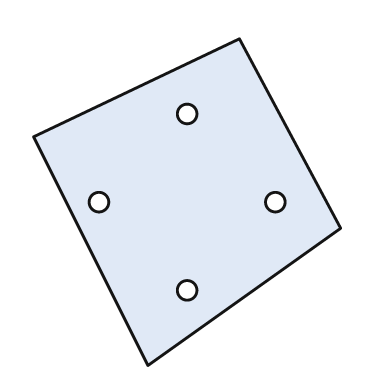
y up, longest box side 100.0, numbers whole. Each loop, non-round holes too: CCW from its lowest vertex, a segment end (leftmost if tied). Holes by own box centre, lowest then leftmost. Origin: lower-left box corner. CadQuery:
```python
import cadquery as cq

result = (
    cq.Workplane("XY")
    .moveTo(35.0, 0.0)
    .lineTo(94.0, 42.0)
    .lineTo(63.0, 100.0)
    .lineTo(0.0, 70.0)
    .close()
    .moveTo(47.0, 23.0)
    .circle(3.0)
    .moveTo(20.0, 50.0)
    .circle(3.0)
    .moveTo(74.0, 50.0)
    .circle(3.0)
    .moveTo(47.0, 77.0)
    .circle(3.0)
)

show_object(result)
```